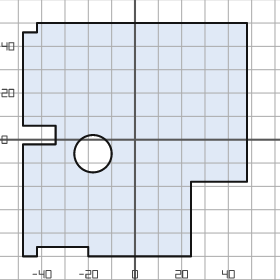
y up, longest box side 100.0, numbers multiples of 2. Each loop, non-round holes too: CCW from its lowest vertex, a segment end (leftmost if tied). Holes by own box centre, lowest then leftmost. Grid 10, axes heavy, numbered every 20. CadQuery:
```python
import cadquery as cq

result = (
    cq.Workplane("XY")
    .moveTo(-48.0, -50.0)
    .lineTo(-42.0, -50.0)
    .lineTo(-42.0, -46.0)
    .lineTo(-20.0, -46.0)
    .lineTo(-20.0, -50.0)
    .lineTo(24.0, -50.0)
    .lineTo(24.0, -18.0)
    .lineTo(48.0, -18.0)
    .lineTo(48.0, 50.0)
    .lineTo(-42.0, 50.0)
    .lineTo(-42.0, 46.0)
    .lineTo(-48.0, 46.0)
    .lineTo(-48.0, 6.0)
    .lineTo(-34.0, 6.0)
    .lineTo(-34.0, -2.0)
    .lineTo(-48.0, -2.0)
    .close()
    .moveTo(-18.0, -6.0)
    .circle(8.0)
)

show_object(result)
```